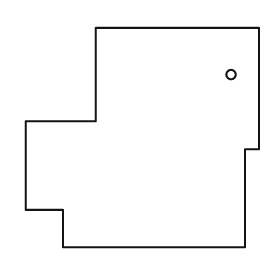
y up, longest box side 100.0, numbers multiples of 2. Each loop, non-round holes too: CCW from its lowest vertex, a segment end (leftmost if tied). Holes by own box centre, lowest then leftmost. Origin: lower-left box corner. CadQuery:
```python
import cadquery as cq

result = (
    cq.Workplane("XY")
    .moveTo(16.0, 0.0)
    .lineTo(94.0, 0.0)
    .lineTo(94.0, 42.0)
    .lineTo(100.0, 42.0)
    .lineTo(100.0, 94.0)
    .lineTo(30.0, 94.0)
    .lineTo(30.0, 54.0)
    .lineTo(0.0, 54.0)
    .lineTo(0.0, 16.0)
    .lineTo(16.0, 16.0)
    .close()
    .moveTo(88.0, 74.0)
    .circle(2.0)
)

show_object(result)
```